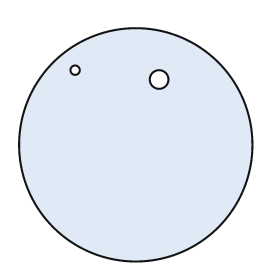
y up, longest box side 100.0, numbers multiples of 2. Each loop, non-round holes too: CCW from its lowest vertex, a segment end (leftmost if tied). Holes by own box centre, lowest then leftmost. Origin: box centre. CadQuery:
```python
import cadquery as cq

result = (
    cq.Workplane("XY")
    .moveTo(0.0, 0.0)
    .circle(50.0)
    .moveTo(10.0, 28.0)
    .circle(4.0)
    .moveTo(-26.0, 32.0)
    .circle(2.0)
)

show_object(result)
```